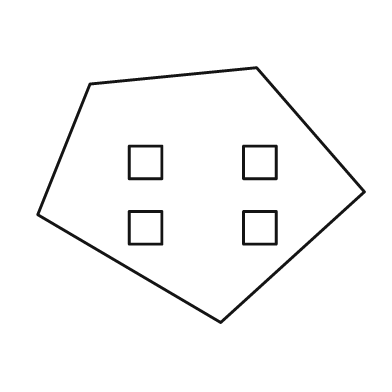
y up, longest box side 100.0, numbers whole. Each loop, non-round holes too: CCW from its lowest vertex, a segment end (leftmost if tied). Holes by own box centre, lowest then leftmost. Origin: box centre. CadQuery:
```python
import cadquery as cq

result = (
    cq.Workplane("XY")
    .moveTo(6.0, -39.0)
    .lineTo(50.0, 1.0)
    .lineTo(17.0, 39.0)
    .lineTo(-34.0, 34.0)
    .lineTo(-50.0, -6.0)
    .close()
    .moveTo(-22.0, -15.0)
    .lineTo(-12.0, -15.0)
    .lineTo(-12.0, -5.0)
    .lineTo(-22.0, -5.0)
    .close()
    .moveTo(13.0, -15.0)
    .lineTo(23.0, -15.0)
    .lineTo(23.0, -5.0)
    .lineTo(13.0, -5.0)
    .close()
    .moveTo(-22.0, 5.0)
    .lineTo(-12.0, 5.0)
    .lineTo(-12.0, 15.0)
    .lineTo(-22.0, 15.0)
    .close()
    .moveTo(13.0, 5.0)
    .lineTo(23.0, 5.0)
    .lineTo(23.0, 15.0)
    .lineTo(13.0, 15.0)
    .close()
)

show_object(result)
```